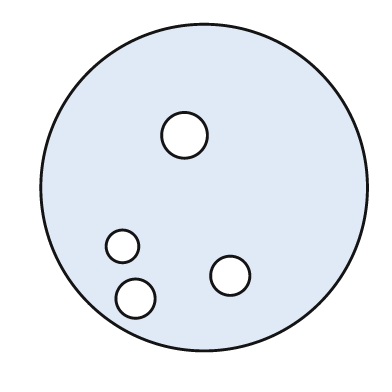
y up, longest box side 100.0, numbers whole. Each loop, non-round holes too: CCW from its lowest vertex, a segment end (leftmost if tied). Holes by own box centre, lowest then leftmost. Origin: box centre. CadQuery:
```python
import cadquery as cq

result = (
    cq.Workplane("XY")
    .moveTo(0.0, 0.0)
    .circle(50.0)
    .moveTo(-21.0, -34.0)
    .circle(6.0)
    .moveTo(8.0, -27.0)
    .circle(6.0)
    .moveTo(-25.0, -18.0)
    .circle(5.0)
    .moveTo(-6.0, 16.0)
    .circle(7.0)
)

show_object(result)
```